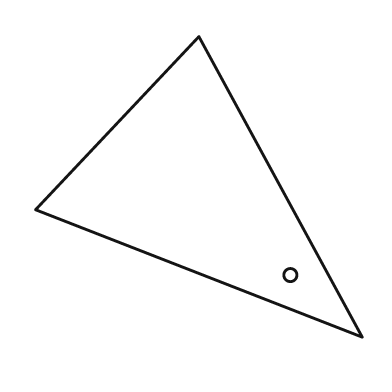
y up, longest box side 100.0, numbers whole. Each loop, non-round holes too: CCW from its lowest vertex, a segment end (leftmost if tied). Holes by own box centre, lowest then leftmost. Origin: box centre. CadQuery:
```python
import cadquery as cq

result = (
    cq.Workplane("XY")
    .moveTo(50.0, -46.0)
    .lineTo(0.0, 46.0)
    .lineTo(-50.0, -7.0)
    .close()
    .moveTo(28.0, -27.0)
    .circle(2.0)
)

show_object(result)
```